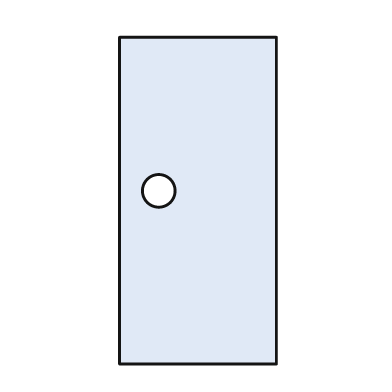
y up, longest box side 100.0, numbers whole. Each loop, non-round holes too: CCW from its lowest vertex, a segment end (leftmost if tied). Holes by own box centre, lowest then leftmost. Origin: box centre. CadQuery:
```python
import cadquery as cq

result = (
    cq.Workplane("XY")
    .moveTo(-24.0, -50.0)
    .lineTo(24.0, -50.0)
    .lineTo(24.0, 50.0)
    .lineTo(-24.0, 50.0)
    .close()
    .moveTo(-12.0, 3.0)
    .circle(5.0)
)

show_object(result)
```